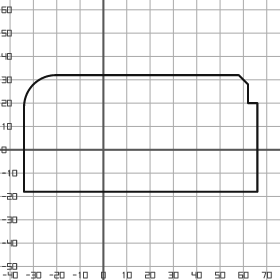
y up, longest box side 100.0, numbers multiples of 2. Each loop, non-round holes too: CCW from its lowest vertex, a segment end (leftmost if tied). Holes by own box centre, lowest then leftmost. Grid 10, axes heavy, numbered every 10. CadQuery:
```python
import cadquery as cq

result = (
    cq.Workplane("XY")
    .moveTo(-34.0, -18.0)
    .lineTo(66.0, -18.0)
    .lineTo(66.0, 20.0)
    .lineTo(62.0, 20.0)
    .lineTo(62.0, 28.0)
    .lineTo(58.0, 32.0)
    .lineTo(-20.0, 32.0)
    .threePointArc((-30.0, 28.0), (-34.0, 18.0))
    .close()
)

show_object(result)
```